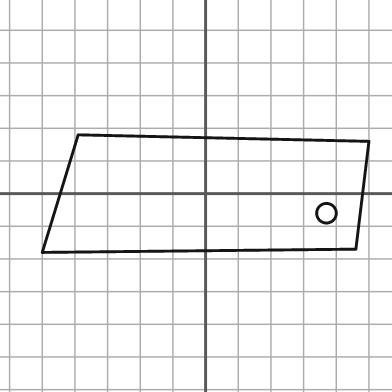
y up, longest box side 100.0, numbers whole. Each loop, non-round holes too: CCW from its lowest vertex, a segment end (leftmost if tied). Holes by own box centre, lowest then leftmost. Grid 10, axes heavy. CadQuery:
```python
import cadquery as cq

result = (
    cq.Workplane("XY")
    .moveTo(-50.0, -18.0)
    .lineTo(46.0, -17.0)
    .lineTo(50.0, 16.0)
    .lineTo(-39.0, 18.0)
    .close()
    .moveTo(37.0, -6.0)
    .circle(3.0)
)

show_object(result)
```